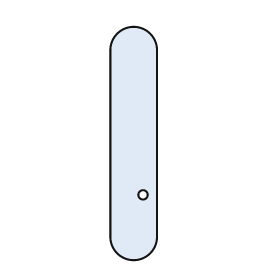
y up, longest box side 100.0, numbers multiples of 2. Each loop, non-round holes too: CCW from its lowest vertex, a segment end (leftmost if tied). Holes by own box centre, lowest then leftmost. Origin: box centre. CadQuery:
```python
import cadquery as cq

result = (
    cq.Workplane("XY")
    .moveTo(-10.0, -40.0)
    .threePointArc((0.0, -50.0), (10.0, -40.0))
    .lineTo(10.0, 40.0)
    .threePointArc((0.0, 50.0), (-10.0, 40.0))
    .close()
    .moveTo(4.0, -22.0)
    .circle(2.0)
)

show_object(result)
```